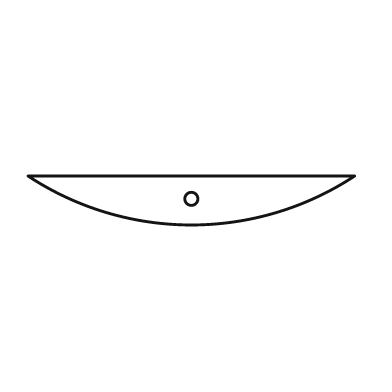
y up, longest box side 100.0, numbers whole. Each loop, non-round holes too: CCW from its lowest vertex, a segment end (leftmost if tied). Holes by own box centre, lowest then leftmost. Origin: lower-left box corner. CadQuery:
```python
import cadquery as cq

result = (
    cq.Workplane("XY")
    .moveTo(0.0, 15.0)
    .threePointArc((50.0, 0.0), (100.0, 15.0))
    .close()
    .moveTo(50.0, 8.0)
    .circle(2.0)
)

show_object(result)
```